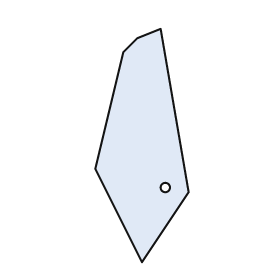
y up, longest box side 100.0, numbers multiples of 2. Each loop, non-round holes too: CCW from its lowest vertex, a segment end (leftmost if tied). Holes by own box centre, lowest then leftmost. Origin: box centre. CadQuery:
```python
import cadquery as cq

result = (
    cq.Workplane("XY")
    .moveTo(0.0, -50.0)
    .lineTo(20.0, -20.0)
    .lineTo(8.0, 50.0)
    .lineTo(-2.0, 46.0)
    .lineTo(-8.0, 40.0)
    .lineTo(-20.0, -10.0)
    .close()
    .moveTo(10.0, -18.0)
    .circle(2.0)
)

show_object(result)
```